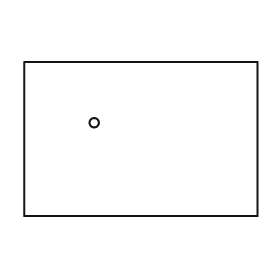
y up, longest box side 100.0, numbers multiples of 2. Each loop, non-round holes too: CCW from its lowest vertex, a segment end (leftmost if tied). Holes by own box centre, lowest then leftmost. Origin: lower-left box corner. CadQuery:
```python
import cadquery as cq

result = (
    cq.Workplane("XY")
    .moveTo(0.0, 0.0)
    .lineTo(100.0, 0.0)
    .lineTo(100.0, 66.0)
    .lineTo(0.0, 66.0)
    .close()
    .moveTo(30.0, 40.0)
    .circle(2.0)
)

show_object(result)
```